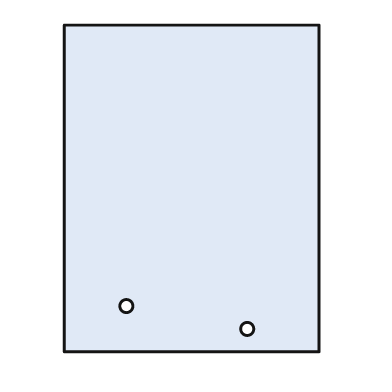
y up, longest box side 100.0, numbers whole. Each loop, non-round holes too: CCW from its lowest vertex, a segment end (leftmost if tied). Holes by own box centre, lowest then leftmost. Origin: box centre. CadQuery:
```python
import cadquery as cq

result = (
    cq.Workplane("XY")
    .moveTo(-39.0, -50.0)
    .lineTo(39.0, -50.0)
    .lineTo(39.0, 50.0)
    .lineTo(-39.0, 50.0)
    .close()
    .moveTo(17.0, -43.0)
    .circle(2.0)
    .moveTo(-20.0, -36.0)
    .circle(2.0)
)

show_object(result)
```